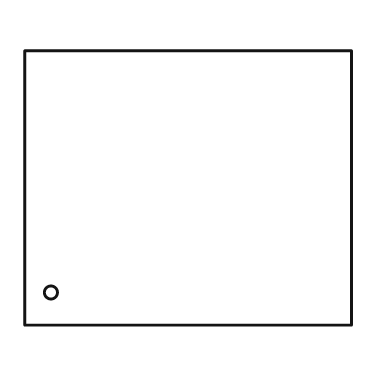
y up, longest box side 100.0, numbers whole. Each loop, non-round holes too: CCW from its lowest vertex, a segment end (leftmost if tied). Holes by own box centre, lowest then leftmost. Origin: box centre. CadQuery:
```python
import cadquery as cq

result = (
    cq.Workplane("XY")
    .moveTo(-50.0, -42.0)
    .lineTo(50.0, -42.0)
    .lineTo(50.0, 42.0)
    .lineTo(-50.0, 42.0)
    .close()
    .moveTo(-42.0, -32.0)
    .circle(2.0)
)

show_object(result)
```